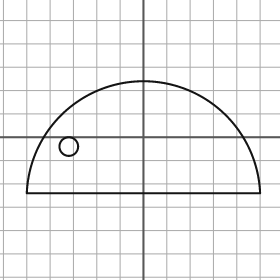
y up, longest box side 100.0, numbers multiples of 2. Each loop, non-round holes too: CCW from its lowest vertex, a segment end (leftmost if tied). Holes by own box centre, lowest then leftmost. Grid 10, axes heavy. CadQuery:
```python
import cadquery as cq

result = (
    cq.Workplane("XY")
    .moveTo(-50.0, -24.0)
    .lineTo(50.0, -24.0)
    .threePointArc((0.0, 24.0), (-50.0, -24.0))
    .close()
    .moveTo(-32.0, -4.0)
    .circle(4.0)
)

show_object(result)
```